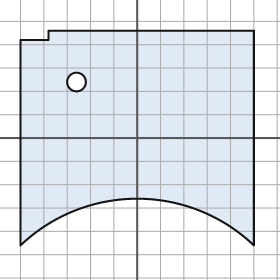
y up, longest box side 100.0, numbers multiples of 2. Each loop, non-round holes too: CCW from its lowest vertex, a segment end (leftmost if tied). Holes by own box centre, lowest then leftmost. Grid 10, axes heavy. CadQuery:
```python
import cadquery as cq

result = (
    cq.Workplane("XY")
    .moveTo(-50.0, -46.0)
    .threePointArc((0.0, -26.0), (50.0, -46.0))
    .lineTo(50.0, 46.0)
    .lineTo(-38.0, 46.0)
    .lineTo(-38.0, 42.0)
    .lineTo(-50.0, 42.0)
    .close()
    .moveTo(-26.0, 24.0)
    .circle(4.0)
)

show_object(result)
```